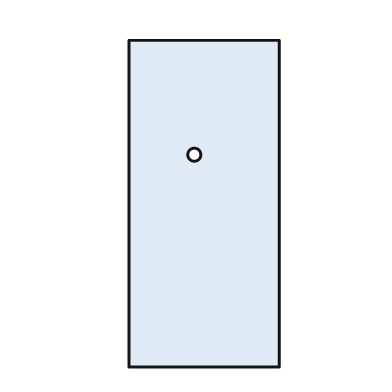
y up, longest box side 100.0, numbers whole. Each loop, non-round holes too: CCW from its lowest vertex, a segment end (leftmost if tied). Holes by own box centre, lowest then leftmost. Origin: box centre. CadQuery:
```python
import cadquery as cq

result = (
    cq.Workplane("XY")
    .moveTo(-23.0, -50.0)
    .lineTo(23.0, -50.0)
    .lineTo(23.0, 50.0)
    .lineTo(-23.0, 50.0)
    .close()
    .moveTo(-3.0, 15.0)
    .circle(2.0)
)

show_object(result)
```